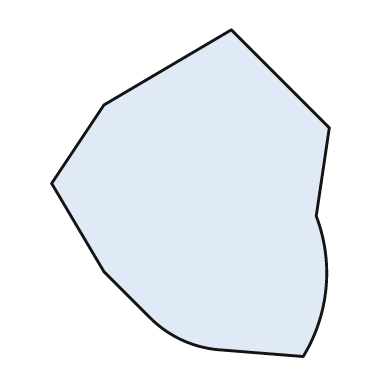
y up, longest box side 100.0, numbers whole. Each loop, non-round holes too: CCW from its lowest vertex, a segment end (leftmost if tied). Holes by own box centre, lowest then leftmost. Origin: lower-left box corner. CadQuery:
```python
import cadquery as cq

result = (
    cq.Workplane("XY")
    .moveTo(77.0, 0.0)
    .threePointArc((84.0, 21.0), (81.0, 43.0))
    .lineTo(85.0, 70.0)
    .lineTo(55.0, 100.0)
    .lineTo(16.0, 77.0)
    .lineTo(0.0, 53.0)
    .lineTo(16.0, 26.0)
    .lineTo(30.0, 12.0)
    .threePointArc((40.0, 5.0), (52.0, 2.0))
    .close()
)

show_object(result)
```